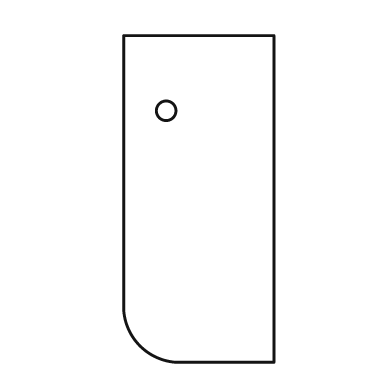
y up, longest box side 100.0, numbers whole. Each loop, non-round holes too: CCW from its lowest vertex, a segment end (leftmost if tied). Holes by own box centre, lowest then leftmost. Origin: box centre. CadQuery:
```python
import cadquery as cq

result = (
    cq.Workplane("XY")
    .moveTo(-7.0, -50.0)
    .lineTo(23.0, -50.0)
    .lineTo(23.0, 50.0)
    .lineTo(-23.0, 50.0)
    .lineTo(-23.0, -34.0)
    .threePointArc((-18.0, -45.0), (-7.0, -50.0))
    .close()
    .moveTo(-10.0, 27.0)
    .circle(3.0)
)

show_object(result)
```